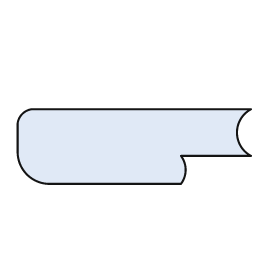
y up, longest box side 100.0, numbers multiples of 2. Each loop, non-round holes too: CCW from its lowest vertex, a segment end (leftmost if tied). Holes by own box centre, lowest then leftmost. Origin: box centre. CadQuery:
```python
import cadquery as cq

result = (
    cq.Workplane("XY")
    .moveTo(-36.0, -16.0)
    .lineTo(20.0, -16.0)
    .threePointArc((22.0, -10.0), (20.0, -4.0))
    .lineTo(50.0, -4.0)
    .threePointArc((44.0, 6.0), (50.0, 16.0))
    .lineTo(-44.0, 16.0)
    .threePointArc((-48.0, 14.0), (-50.0, 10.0))
    .lineTo(-50.0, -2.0)
    .threePointArc((-46.0, -12.0), (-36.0, -16.0))
    .close()
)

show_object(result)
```